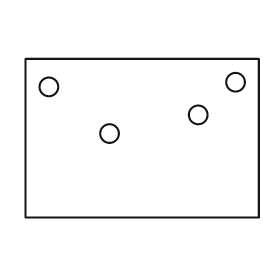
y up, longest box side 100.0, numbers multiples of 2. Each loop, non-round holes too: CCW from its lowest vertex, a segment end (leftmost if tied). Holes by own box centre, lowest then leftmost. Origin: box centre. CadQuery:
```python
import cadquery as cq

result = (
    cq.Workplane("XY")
    .moveTo(-50.0, -34.0)
    .lineTo(50.0, -34.0)
    .lineTo(50.0, 34.0)
    .lineTo(-50.0, 34.0)
    .close()
    .moveTo(-14.0, 2.0)
    .circle(4.0)
    .moveTo(24.0, 10.0)
    .circle(4.0)
    .moveTo(-40.0, 22.0)
    .circle(4.0)
    .moveTo(40.0, 24.0)
    .circle(4.0)
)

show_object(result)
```